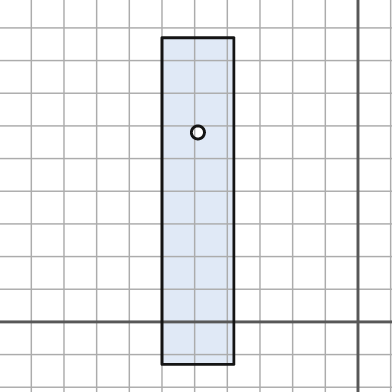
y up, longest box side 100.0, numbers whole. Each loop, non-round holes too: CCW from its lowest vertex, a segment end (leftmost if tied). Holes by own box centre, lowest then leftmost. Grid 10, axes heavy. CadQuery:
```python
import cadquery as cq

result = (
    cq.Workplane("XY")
    .moveTo(-60.0, -13.0)
    .lineTo(-38.0, -13.0)
    .lineTo(-38.0, 87.0)
    .lineTo(-60.0, 87.0)
    .close()
    .moveTo(-49.0, 58.0)
    .circle(2.0)
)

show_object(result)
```